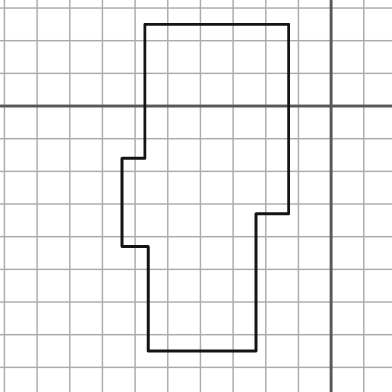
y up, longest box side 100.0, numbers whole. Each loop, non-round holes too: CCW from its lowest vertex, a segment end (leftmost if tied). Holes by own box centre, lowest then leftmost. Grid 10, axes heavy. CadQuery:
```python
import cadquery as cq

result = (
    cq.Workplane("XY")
    .moveTo(-56.0, -75.0)
    .lineTo(-23.0, -75.0)
    .lineTo(-23.0, -33.0)
    .lineTo(-13.0, -33.0)
    .lineTo(-13.0, 25.0)
    .lineTo(-57.0, 25.0)
    .lineTo(-57.0, -16.0)
    .lineTo(-64.0, -16.0)
    .lineTo(-64.0, -43.0)
    .lineTo(-56.0, -43.0)
    .close()
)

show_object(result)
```